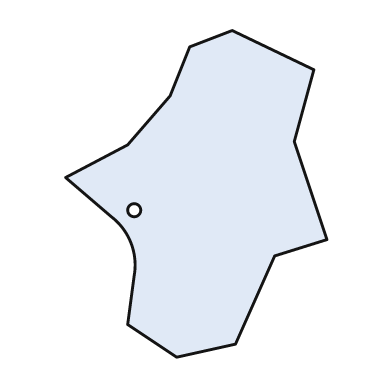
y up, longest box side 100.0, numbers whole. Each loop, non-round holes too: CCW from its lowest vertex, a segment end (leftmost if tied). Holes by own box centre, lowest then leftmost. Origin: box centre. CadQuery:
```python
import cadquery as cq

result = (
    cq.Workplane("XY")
    .moveTo(-6.0, -50.0)
    .lineTo(12.0, -46.0)
    .lineTo(24.0, -19.0)
    .lineTo(40.0, -14.0)
    .lineTo(30.0, 16.0)
    .lineTo(36.0, 38.0)
    .lineTo(11.0, 50.0)
    .lineTo(-2.0, 45.0)
    .lineTo(-8.0, 30.0)
    .lineTo(-21.0, 15.0)
    .lineTo(-40.0, 5.0)
    .lineTo(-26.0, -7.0)
    .threePointArc((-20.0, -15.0), (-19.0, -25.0))
    .lineTo(-21.0, -40.0)
    .close()
    .moveTo(-19.0, -5.0)
    .circle(2.0)
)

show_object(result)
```